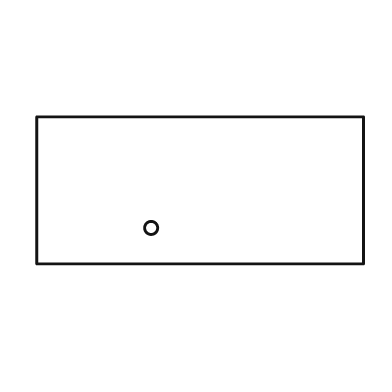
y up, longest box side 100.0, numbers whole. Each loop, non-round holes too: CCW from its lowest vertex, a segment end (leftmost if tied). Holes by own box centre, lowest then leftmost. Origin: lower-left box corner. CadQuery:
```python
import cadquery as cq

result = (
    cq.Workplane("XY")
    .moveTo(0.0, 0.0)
    .lineTo(100.0, 0.0)
    .lineTo(100.0, 45.0)
    .lineTo(0.0, 45.0)
    .close()
    .moveTo(35.0, 11.0)
    .circle(2.0)
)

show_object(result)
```